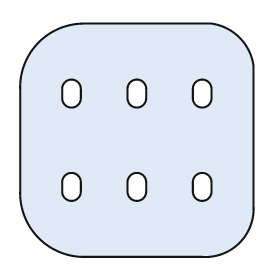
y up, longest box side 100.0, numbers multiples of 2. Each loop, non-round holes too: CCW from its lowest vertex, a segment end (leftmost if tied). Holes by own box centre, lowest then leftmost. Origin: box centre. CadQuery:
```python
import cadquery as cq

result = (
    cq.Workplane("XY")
    .moveTo(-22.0, -50.0)
    .lineTo(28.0, -50.0)
    .threePointArc((44.0, -44.0), (50.0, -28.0))
    .lineTo(50.0, 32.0)
    .threePointArc((44.0, 44.0), (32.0, 50.0))
    .lineTo(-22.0, 50.0)
    .threePointArc((-42.0, 42.0), (-50.0, 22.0))
    .lineTo(-50.0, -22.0)
    .threePointArc((-42.0, -42.0), (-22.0, -50.0))
    .close()
    .moveTo(-32.0, -22.0)
    .threePointArc((-28.0, -26.0), (-24.0, -22.0))
    .lineTo(-24.0, -18.0)
    .threePointArc((-28.0, -14.0), (-32.0, -18.0))
    .close()
    .moveTo(-4.0, -22.0)
    .threePointArc((0.0, -26.0), (4.0, -22.0))
    .lineTo(4.0, -18.0)
    .threePointArc((0.0, -14.0), (-4.0, -18.0))
    .close()
    .moveTo(24.0, -22.0)
    .threePointArc((28.0, -26.0), (32.0, -22.0))
    .lineTo(32.0, -18.0)
    .threePointArc((28.0, -14.0), (24.0, -18.0))
    .close()
    .moveTo(-32.0, 18.0)
    .threePointArc((-28.0, 14.0), (-24.0, 18.0))
    .lineTo(-24.0, 22.0)
    .threePointArc((-28.0, 26.0), (-32.0, 22.0))
    .close()
    .moveTo(-4.0, 18.0)
    .threePointArc((0.0, 14.0), (4.0, 18.0))
    .lineTo(4.0, 22.0)
    .threePointArc((0.0, 26.0), (-4.0, 22.0))
    .close()
    .moveTo(24.0, 18.0)
    .threePointArc((28.0, 14.0), (32.0, 18.0))
    .lineTo(32.0, 22.0)
    .threePointArc((28.0, 26.0), (24.0, 22.0))
    .close()
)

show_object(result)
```